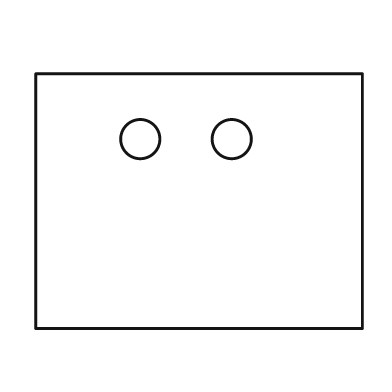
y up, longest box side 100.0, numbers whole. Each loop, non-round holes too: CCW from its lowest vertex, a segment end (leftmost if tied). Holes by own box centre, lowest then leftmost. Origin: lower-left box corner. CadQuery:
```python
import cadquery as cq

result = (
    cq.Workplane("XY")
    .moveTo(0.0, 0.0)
    .lineTo(100.0, 0.0)
    .lineTo(100.0, 78.0)
    .lineTo(0.0, 78.0)
    .close()
    .moveTo(32.0, 58.0)
    .circle(6.0)
    .moveTo(60.0, 58.0)
    .circle(6.0)
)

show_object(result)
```